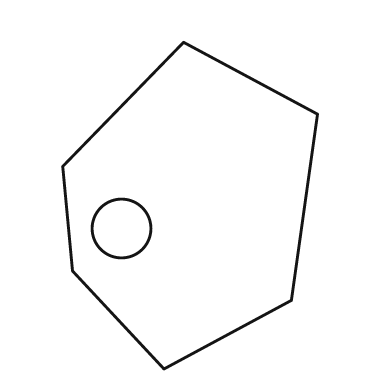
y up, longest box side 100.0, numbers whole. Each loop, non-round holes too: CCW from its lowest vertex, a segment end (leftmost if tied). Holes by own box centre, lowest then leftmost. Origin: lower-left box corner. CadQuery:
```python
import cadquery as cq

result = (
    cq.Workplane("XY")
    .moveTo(31.0, 0.0)
    .lineTo(70.0, 21.0)
    .lineTo(78.0, 78.0)
    .lineTo(37.0, 100.0)
    .lineTo(0.0, 62.0)
    .lineTo(3.0, 30.0)
    .close()
    .moveTo(18.0, 43.0)
    .circle(9.0)
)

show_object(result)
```